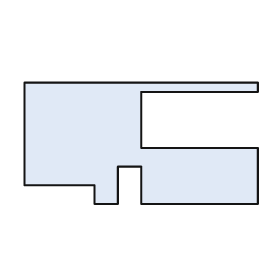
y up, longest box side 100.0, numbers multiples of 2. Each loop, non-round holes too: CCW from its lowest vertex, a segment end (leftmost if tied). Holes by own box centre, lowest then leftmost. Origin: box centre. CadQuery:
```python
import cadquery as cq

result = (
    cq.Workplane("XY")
    .moveTo(-20.0, -26.0)
    .lineTo(-10.0, -26.0)
    .lineTo(-10.0, -10.0)
    .lineTo(0.0, -10.0)
    .lineTo(0.0, -26.0)
    .lineTo(50.0, -26.0)
    .lineTo(50.0, -2.0)
    .lineTo(0.0, -2.0)
    .lineTo(0.0, 22.0)
    .lineTo(50.0, 22.0)
    .lineTo(50.0, 26.0)
    .lineTo(-50.0, 26.0)
    .lineTo(-50.0, -18.0)
    .lineTo(-20.0, -18.0)
    .close()
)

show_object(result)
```